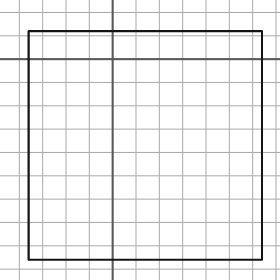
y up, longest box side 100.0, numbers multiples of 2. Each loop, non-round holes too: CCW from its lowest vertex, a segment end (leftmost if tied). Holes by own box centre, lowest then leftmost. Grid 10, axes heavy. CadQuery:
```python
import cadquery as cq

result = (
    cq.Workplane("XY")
    .moveTo(-36.0, -86.0)
    .lineTo(64.0, -86.0)
    .lineTo(64.0, 12.0)
    .lineTo(-36.0, 12.0)
    .close()
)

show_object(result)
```